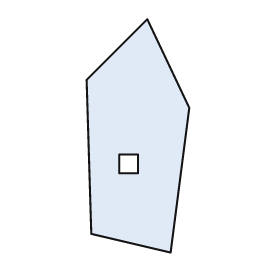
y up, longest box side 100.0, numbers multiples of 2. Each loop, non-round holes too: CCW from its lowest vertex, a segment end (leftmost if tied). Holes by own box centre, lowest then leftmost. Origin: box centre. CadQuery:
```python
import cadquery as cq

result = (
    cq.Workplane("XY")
    .moveTo(14.0, -50.0)
    .lineTo(22.0, 12.0)
    .lineTo(4.0, 50.0)
    .lineTo(-22.0, 24.0)
    .lineTo(-20.0, -42.0)
    .close()
    .moveTo(-8.0, -16.0)
    .lineTo(0.0, -16.0)
    .lineTo(0.0, -8.0)
    .lineTo(-8.0, -8.0)
    .close()
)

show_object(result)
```